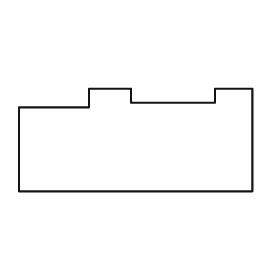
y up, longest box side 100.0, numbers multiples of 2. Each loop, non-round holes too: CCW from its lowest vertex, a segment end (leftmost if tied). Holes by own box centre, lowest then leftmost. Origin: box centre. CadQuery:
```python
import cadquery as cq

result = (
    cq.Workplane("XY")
    .moveTo(-50.0, -22.0)
    .lineTo(50.0, -22.0)
    .lineTo(50.0, 22.0)
    .lineTo(34.0, 22.0)
    .lineTo(34.0, 16.0)
    .lineTo(-2.0, 16.0)
    .lineTo(-2.0, 22.0)
    .lineTo(-20.0, 22.0)
    .lineTo(-20.0, 14.0)
    .lineTo(-50.0, 14.0)
    .close()
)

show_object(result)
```